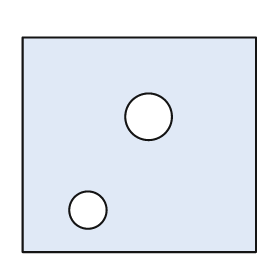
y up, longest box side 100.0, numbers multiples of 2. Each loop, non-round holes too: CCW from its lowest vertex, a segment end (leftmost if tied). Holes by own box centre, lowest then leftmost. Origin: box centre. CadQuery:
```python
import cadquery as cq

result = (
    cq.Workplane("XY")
    .moveTo(-50.0, -46.0)
    .lineTo(50.0, -46.0)
    .lineTo(50.0, 46.0)
    .lineTo(-50.0, 46.0)
    .close()
    .moveTo(-22.0, -28.0)
    .circle(8.0)
    .moveTo(4.0, 12.0)
    .circle(10.0)
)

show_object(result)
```